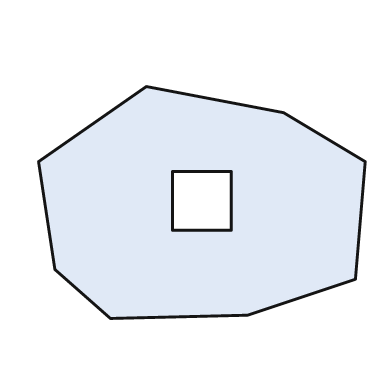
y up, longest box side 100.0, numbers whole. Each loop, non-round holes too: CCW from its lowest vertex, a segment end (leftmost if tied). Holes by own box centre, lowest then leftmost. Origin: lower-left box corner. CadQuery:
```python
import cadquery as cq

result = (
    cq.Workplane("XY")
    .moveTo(22.0, 0.0)
    .lineTo(64.0, 1.0)
    .lineTo(97.0, 12.0)
    .lineTo(100.0, 48.0)
    .lineTo(75.0, 63.0)
    .lineTo(33.0, 71.0)
    .lineTo(0.0, 48.0)
    .lineTo(5.0, 15.0)
    .close()
    .moveTo(41.0, 27.0)
    .lineTo(59.0, 27.0)
    .lineTo(59.0, 45.0)
    .lineTo(41.0, 45.0)
    .close()
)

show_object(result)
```